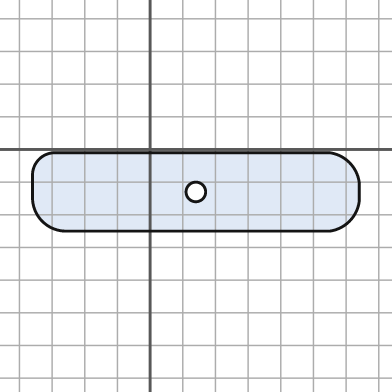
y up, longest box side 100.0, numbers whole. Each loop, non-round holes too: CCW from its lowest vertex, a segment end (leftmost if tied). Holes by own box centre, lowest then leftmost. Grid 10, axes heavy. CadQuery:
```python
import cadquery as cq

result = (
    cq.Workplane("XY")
    .moveTo(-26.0, -25.0)
    .lineTo(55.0, -25.0)
    .threePointArc((61.0, -22.0), (64.0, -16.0))
    .lineTo(64.0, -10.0)
    .threePointArc((61.0, -4.0), (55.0, -1.0))
    .lineTo(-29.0, -1.0)
    .threePointArc((-34.0, -3.0), (-36.0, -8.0))
    .lineTo(-36.0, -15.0)
    .threePointArc((-33.0, -22.0), (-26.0, -25.0))
    .close()
    .moveTo(14.0, -13.0)
    .circle(3.0)
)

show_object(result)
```